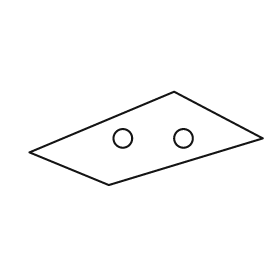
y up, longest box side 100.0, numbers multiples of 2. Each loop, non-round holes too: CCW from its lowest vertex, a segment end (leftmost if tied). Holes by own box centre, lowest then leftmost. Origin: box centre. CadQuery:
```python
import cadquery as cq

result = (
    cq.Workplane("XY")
    .moveTo(-16.0, -20.0)
    .lineTo(50.0, 0.0)
    .lineTo(12.0, 20.0)
    .lineTo(-50.0, -6.0)
    .close()
    .moveTo(-10.0, 0.0)
    .circle(4.0)
    .moveTo(16.0, 0.0)
    .circle(4.0)
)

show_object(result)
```